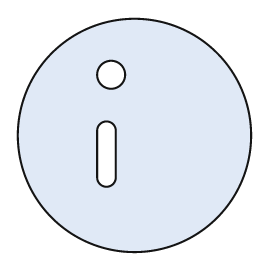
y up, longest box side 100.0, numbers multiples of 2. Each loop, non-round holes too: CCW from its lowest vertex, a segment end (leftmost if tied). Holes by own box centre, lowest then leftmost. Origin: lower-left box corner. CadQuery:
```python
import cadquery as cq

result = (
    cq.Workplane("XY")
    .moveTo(50.0, 50.0)
    .circle(50.0)
    .moveTo(34.0, 32.0)
    .threePointArc((38.0, 28.0), (42.0, 32.0))
    .lineTo(42.0, 52.0)
    .threePointArc((38.0, 56.0), (34.0, 52.0))
    .close()
    .moveTo(40.0, 76.0)
    .circle(6.0)
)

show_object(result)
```